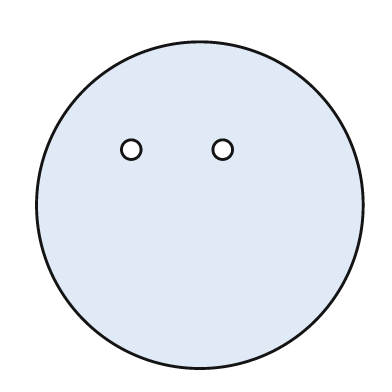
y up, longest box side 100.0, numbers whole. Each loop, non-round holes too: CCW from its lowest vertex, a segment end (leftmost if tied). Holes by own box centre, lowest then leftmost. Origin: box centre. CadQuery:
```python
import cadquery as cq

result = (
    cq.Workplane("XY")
    .moveTo(0.0, 0.0)
    .circle(50.0)
    .moveTo(-21.0, 17.0)
    .circle(3.0)
    .moveTo(7.0, 17.0)
    .circle(3.0)
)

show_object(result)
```